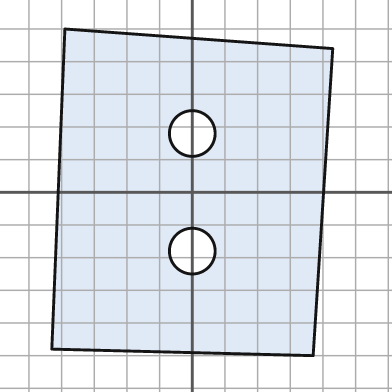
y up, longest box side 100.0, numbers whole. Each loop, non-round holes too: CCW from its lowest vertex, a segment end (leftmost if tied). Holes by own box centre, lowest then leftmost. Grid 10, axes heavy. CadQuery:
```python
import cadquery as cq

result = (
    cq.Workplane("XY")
    .moveTo(37.0, -50.0)
    .lineTo(43.0, 44.0)
    .lineTo(-39.0, 50.0)
    .lineTo(-43.0, -48.0)
    .close()
    .moveTo(0.0, -18.0)
    .circle(7.0)
    .moveTo(0.0, 18.0)
    .circle(7.0)
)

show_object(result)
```